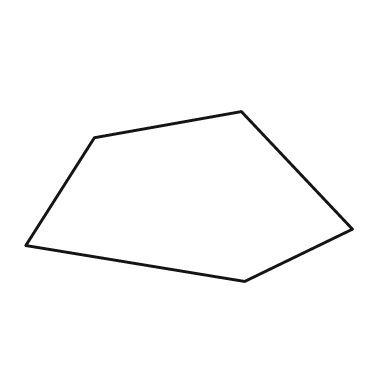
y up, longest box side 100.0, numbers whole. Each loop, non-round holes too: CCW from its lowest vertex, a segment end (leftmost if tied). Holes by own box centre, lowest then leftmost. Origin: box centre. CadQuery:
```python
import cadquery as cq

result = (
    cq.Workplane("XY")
    .moveTo(17.0, -26.0)
    .lineTo(50.0, -10.0)
    .lineTo(16.0, 26.0)
    .lineTo(-29.0, 18.0)
    .lineTo(-50.0, -15.0)
    .close()
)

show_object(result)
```